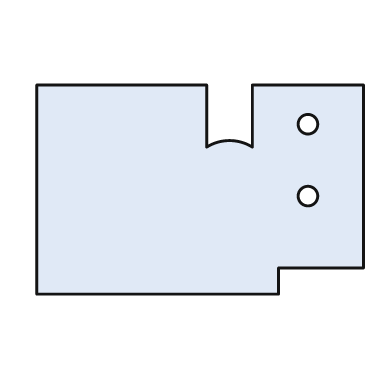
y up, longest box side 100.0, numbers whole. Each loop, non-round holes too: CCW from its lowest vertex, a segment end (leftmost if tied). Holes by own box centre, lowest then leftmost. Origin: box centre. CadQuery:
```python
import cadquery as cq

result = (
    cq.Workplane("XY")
    .moveTo(-50.0, -32.0)
    .lineTo(24.0, -32.0)
    .lineTo(24.0, -24.0)
    .lineTo(50.0, -24.0)
    .lineTo(50.0, 32.0)
    .lineTo(16.0, 32.0)
    .lineTo(16.0, 13.0)
    .threePointArc((9.0, 15.0), (2.0, 13.0))
    .lineTo(2.0, 32.0)
    .lineTo(-50.0, 32.0)
    .close()
    .moveTo(33.0, -2.0)
    .circle(3.0)
    .moveTo(33.0, 20.0)
    .circle(3.0)
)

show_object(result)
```